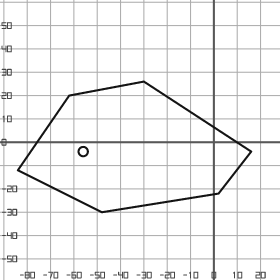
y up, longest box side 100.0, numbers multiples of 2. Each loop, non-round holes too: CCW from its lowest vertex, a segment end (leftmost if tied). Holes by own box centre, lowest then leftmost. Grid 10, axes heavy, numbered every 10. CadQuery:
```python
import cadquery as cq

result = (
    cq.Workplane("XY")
    .moveTo(-48.0, -30.0)
    .lineTo(2.0, -22.0)
    .lineTo(16.0, -4.0)
    .lineTo(-30.0, 26.0)
    .lineTo(-62.0, 20.0)
    .lineTo(-84.0, -12.0)
    .close()
    .moveTo(-56.0, -4.0)
    .circle(2.0)
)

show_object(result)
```